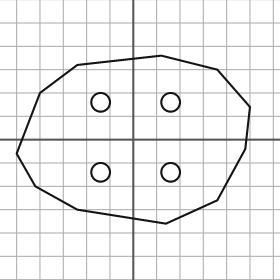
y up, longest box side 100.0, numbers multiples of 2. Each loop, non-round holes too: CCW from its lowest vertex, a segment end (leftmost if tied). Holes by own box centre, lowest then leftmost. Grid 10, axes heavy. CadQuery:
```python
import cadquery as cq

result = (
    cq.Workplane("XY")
    .moveTo(14.0, -36.0)
    .lineTo(36.0, -26.0)
    .lineTo(48.0, -4.0)
    .lineTo(50.0, 14.0)
    .lineTo(36.0, 30.0)
    .lineTo(12.0, 36.0)
    .lineTo(-24.0, 32.0)
    .lineTo(-40.0, 20.0)
    .lineTo(-50.0, -6.0)
    .lineTo(-42.0, -20.0)
    .lineTo(-24.0, -30.0)
    .close()
    .moveTo(-14.0, -14.0)
    .circle(4.0)
    .moveTo(16.0, -14.0)
    .circle(4.0)
    .moveTo(-14.0, 16.0)
    .circle(4.0)
    .moveTo(16.0, 16.0)
    .circle(4.0)
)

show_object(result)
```